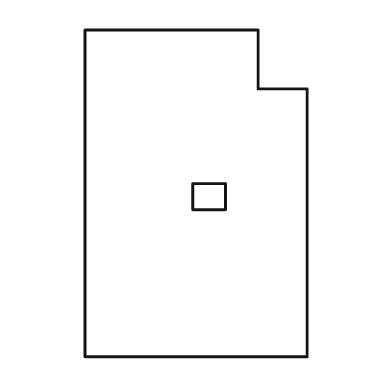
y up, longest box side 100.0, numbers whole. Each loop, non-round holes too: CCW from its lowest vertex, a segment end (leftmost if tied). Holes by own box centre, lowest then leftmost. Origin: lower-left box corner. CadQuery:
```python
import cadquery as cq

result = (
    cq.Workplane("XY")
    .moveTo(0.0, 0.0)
    .lineTo(68.0, 0.0)
    .lineTo(68.0, 82.0)
    .lineTo(53.0, 82.0)
    .lineTo(53.0, 100.0)
    .lineTo(0.0, 100.0)
    .close()
    .moveTo(33.0, 45.0)
    .lineTo(43.0, 45.0)
    .lineTo(43.0, 53.0)
    .lineTo(33.0, 53.0)
    .close()
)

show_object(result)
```